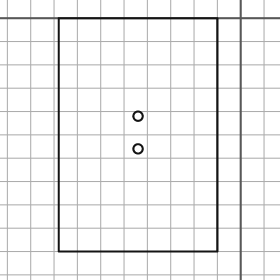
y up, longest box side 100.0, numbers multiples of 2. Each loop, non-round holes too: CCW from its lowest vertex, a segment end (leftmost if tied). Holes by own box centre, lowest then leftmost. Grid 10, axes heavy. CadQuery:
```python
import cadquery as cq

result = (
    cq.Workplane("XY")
    .moveTo(-78.0, -100.0)
    .lineTo(-10.0, -100.0)
    .lineTo(-10.0, 0.0)
    .lineTo(-78.0, 0.0)
    .close()
    .moveTo(-44.0, -56.0)
    .circle(2.0)
    .moveTo(-44.0, -42.0)
    .circle(2.0)
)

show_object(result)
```